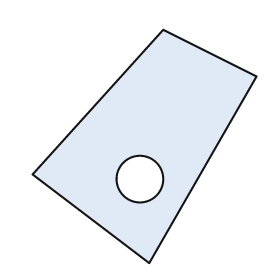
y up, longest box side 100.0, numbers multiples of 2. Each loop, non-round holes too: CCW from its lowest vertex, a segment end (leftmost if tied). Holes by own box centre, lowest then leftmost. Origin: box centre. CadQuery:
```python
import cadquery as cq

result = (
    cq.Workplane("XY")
    .moveTo(2.0, -50.0)
    .lineTo(48.0, 30.0)
    .lineTo(8.0, 50.0)
    .lineTo(-48.0, -12.0)
    .close()
    .moveTo(-2.0, -14.0)
    .circle(10.0)
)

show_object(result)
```